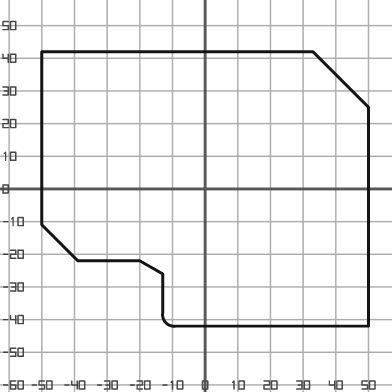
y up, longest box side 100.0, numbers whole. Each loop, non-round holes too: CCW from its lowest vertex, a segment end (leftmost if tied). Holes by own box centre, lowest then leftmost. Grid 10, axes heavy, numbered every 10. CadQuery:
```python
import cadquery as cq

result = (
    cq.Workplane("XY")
    .moveTo(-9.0, -42.0)
    .lineTo(50.0, -42.0)
    .lineTo(50.0, 25.0)
    .lineTo(33.0, 42.0)
    .lineTo(-50.0, 42.0)
    .lineTo(-50.0, -11.0)
    .lineTo(-39.0, -22.0)
    .lineTo(-20.0, -22.0)
    .lineTo(-13.0, -26.0)
    .lineTo(-13.0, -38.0)
    .threePointArc((-12.0, -41.0), (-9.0, -42.0))
    .close()
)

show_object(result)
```